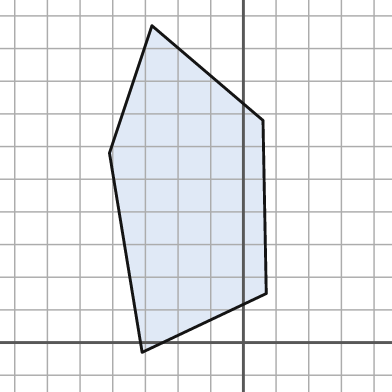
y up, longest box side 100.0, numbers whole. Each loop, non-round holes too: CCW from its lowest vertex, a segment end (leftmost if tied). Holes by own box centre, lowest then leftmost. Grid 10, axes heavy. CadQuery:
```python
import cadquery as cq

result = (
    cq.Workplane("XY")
    .moveTo(-31.0, -3.0)
    .lineTo(7.0, 15.0)
    .lineTo(6.0, 68.0)
    .lineTo(-28.0, 97.0)
    .lineTo(-41.0, 58.0)
    .close()
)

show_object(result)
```